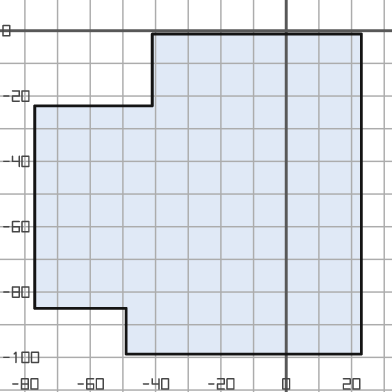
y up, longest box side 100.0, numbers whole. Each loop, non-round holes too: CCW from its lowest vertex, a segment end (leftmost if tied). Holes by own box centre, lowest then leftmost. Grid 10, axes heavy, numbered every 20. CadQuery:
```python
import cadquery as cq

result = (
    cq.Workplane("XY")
    .moveTo(-49.0, -99.0)
    .lineTo(23.0, -99.0)
    .lineTo(23.0, -1.0)
    .lineTo(-41.0, -1.0)
    .lineTo(-41.0, -23.0)
    .lineTo(-77.0, -23.0)
    .lineTo(-77.0, -85.0)
    .lineTo(-49.0, -85.0)
    .close()
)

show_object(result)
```